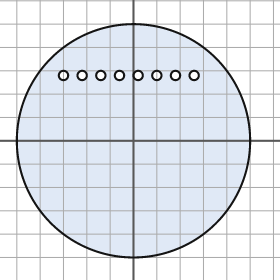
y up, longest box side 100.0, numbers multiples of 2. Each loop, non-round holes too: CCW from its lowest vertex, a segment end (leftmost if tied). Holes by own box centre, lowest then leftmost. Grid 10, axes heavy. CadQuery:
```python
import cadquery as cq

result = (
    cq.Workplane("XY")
    .moveTo(0.0, 0.0)
    .circle(50.0)
    .moveTo(-30.0, 28.0)
    .circle(2.0)
    .moveTo(-22.0, 28.0)
    .circle(2.0)
    .moveTo(-14.0, 28.0)
    .circle(2.0)
    .moveTo(-6.0, 28.0)
    .circle(2.0)
    .moveTo(2.0, 28.0)
    .circle(2.0)
    .moveTo(10.0, 28.0)
    .circle(2.0)
    .moveTo(18.0, 28.0)
    .circle(2.0)
    .moveTo(26.0, 28.0)
    .circle(2.0)
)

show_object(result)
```